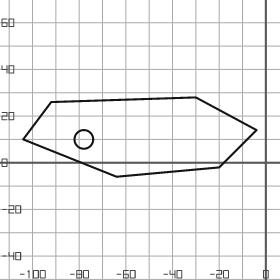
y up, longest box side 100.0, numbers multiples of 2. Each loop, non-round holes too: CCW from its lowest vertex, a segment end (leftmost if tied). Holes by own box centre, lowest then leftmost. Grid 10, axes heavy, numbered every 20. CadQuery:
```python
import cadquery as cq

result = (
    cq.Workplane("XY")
    .moveTo(-64.0, -6.0)
    .lineTo(-20.0, -2.0)
    .lineTo(-4.0, 14.0)
    .lineTo(-30.0, 28.0)
    .lineTo(-92.0, 26.0)
    .lineTo(-104.0, 10.0)
    .close()
    .moveTo(-78.0, 10.0)
    .circle(4.0)
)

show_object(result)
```